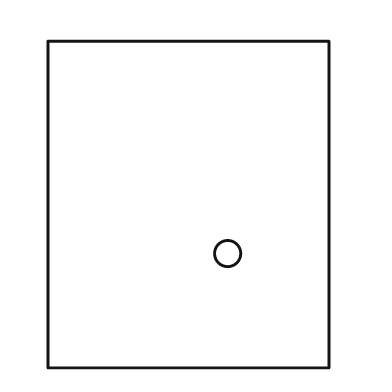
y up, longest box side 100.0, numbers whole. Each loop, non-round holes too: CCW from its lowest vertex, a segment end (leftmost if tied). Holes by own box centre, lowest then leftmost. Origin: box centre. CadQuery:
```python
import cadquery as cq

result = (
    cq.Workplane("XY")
    .moveTo(-43.0, -50.0)
    .lineTo(43.0, -50.0)
    .lineTo(43.0, 50.0)
    .lineTo(-43.0, 50.0)
    .close()
    .moveTo(12.0, -15.0)
    .circle(4.0)
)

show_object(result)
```